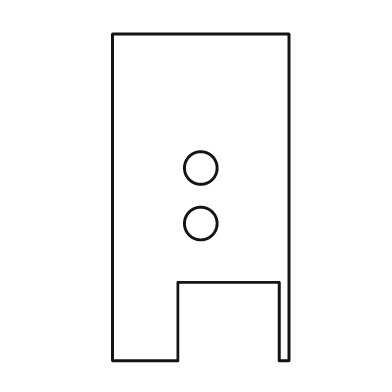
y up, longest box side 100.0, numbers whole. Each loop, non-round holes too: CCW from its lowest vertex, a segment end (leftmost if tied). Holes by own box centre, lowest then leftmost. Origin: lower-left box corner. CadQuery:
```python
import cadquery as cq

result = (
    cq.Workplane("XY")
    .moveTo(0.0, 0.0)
    .lineTo(20.0, 0.0)
    .lineTo(20.0, 24.0)
    .lineTo(51.0, 24.0)
    .lineTo(51.0, 0.0)
    .lineTo(54.0, 0.0)
    .lineTo(54.0, 100.0)
    .lineTo(0.0, 100.0)
    .close()
    .moveTo(27.0, 42.0)
    .circle(5.0)
    .moveTo(27.0, 59.0)
    .circle(5.0)
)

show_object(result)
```